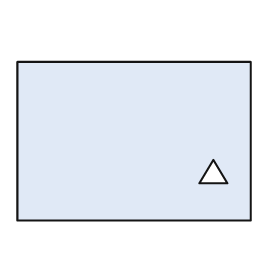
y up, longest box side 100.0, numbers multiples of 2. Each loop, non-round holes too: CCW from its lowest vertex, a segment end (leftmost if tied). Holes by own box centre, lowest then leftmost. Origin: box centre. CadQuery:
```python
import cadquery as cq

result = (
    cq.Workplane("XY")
    .moveTo(-50.0, -34.0)
    .lineTo(50.0, -34.0)
    .lineTo(50.0, 34.0)
    .lineTo(-50.0, 34.0)
    .close()
    .moveTo(28.0, -18.0)
    .lineTo(40.0, -18.0)
    .lineTo(34.0, -8.0)
    .close()
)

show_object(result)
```